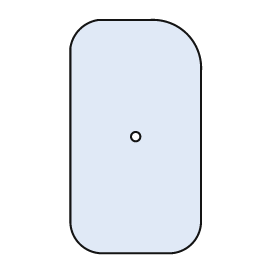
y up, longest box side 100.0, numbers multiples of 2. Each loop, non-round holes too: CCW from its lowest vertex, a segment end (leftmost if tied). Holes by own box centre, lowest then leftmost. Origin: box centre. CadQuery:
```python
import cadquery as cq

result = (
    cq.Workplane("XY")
    .moveTo(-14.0, -50.0)
    .lineTo(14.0, -50.0)
    .threePointArc((24.0, -46.0), (28.0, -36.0))
    .lineTo(28.0, 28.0)
    .threePointArc((22.0, 44.0), (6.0, 50.0))
    .lineTo(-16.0, 50.0)
    .threePointArc((-24.0, 46.0), (-28.0, 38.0))
    .lineTo(-28.0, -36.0)
    .threePointArc((-24.0, -46.0), (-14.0, -50.0))
    .close()
    .moveTo(0.0, 0.0)
    .circle(2.0)
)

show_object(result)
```